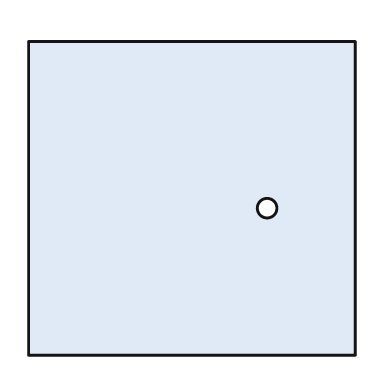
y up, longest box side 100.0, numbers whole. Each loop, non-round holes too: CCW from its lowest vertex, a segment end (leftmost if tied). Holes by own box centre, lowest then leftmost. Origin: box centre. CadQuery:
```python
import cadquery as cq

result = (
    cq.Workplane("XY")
    .moveTo(-50.0, -48.0)
    .lineTo(50.0, -48.0)
    .lineTo(50.0, 48.0)
    .lineTo(-50.0, 48.0)
    .close()
    .moveTo(23.0, -3.0)
    .circle(3.0)
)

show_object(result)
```